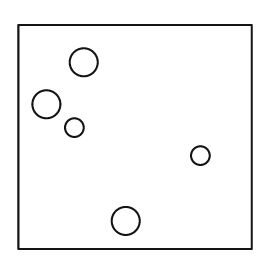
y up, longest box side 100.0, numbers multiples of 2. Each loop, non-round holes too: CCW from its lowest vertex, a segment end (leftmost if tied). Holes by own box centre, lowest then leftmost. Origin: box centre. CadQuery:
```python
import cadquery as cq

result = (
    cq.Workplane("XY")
    .moveTo(-50.0, -48.0)
    .lineTo(50.0, -48.0)
    .lineTo(50.0, 48.0)
    .lineTo(-50.0, 48.0)
    .close()
    .moveTo(-4.0, -36.0)
    .circle(6.0)
    .moveTo(28.0, -8.0)
    .circle(4.0)
    .moveTo(-26.0, 4.0)
    .circle(4.0)
    .moveTo(-38.0, 14.0)
    .circle(6.0)
    .moveTo(-22.0, 32.0)
    .circle(6.0)
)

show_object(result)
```